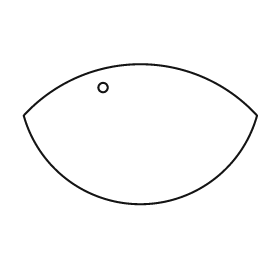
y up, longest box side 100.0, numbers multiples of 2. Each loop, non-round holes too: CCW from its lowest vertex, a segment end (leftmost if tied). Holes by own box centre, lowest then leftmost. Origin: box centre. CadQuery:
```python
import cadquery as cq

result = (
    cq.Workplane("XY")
    .moveTo(-50.0, 8.0)
    .threePointArc((0.0, -30.0), (50.0, 8.0))
    .threePointArc((0.0, 30.0), (-50.0, 8.0))
    .close()
    .moveTo(-16.0, 20.0)
    .circle(2.0)
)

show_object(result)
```